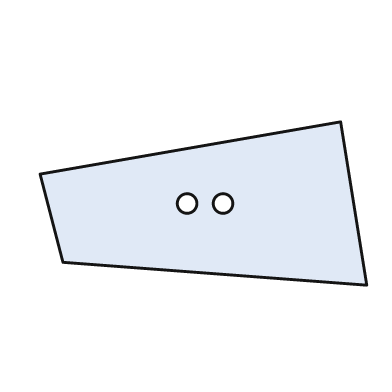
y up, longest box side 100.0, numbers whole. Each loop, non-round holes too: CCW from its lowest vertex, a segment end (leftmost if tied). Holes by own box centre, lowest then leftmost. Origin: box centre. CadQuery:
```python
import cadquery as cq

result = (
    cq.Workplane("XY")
    .moveTo(50.0, -25.0)
    .lineTo(42.0, 25.0)
    .lineTo(-50.0, 9.0)
    .lineTo(-43.0, -18.0)
    .close()
    .moveTo(-5.0, 0.0)
    .circle(3.0)
    .moveTo(6.0, 0.0)
    .circle(3.0)
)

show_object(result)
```